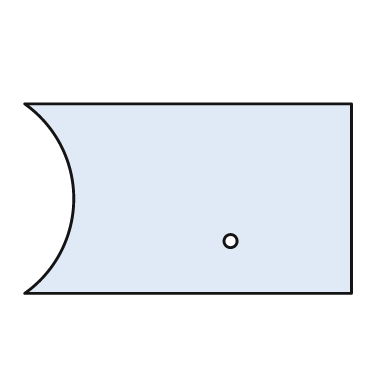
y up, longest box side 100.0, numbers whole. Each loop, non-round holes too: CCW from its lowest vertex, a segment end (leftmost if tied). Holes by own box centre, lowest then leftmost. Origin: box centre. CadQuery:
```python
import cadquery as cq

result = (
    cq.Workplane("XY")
    .moveTo(-50.0, -29.0)
    .lineTo(50.0, -29.0)
    .lineTo(50.0, 29.0)
    .lineTo(-50.0, 29.0)
    .threePointArc((-35.0, 0.0), (-50.0, -29.0))
    .close()
    .moveTo(13.0, -13.0)
    .circle(2.0)
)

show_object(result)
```